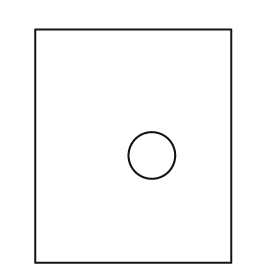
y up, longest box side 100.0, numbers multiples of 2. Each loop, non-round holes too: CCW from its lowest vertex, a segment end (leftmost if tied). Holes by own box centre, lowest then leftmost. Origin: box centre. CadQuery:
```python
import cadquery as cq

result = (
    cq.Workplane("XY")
    .moveTo(-42.0, -50.0)
    .lineTo(42.0, -50.0)
    .lineTo(42.0, 50.0)
    .lineTo(-42.0, 50.0)
    .close()
    .moveTo(8.0, -4.0)
    .circle(10.0)
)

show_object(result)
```